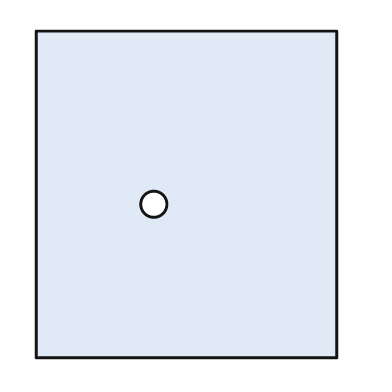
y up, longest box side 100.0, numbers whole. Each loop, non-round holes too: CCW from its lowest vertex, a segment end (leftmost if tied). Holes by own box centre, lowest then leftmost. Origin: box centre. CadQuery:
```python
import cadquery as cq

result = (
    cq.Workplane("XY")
    .moveTo(-46.0, -50.0)
    .lineTo(46.0, -50.0)
    .lineTo(46.0, 50.0)
    .lineTo(-46.0, 50.0)
    .close()
    .moveTo(-10.0, -3.0)
    .circle(4.0)
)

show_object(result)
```